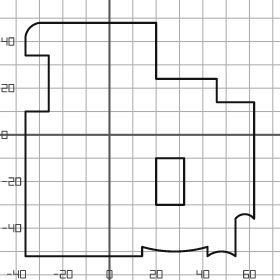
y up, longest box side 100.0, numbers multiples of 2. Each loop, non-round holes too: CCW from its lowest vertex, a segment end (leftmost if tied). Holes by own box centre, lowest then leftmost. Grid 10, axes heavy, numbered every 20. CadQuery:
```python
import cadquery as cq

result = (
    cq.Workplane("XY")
    .moveTo(-36.0, -52.0)
    .lineTo(14.0, -52.0)
    .lineTo(14.0, -48.0)
    .threePointArc((28.0, -50.0), (42.0, -48.0))
    .lineTo(42.0, -52.0)
    .threePointArc((48.0, -50.0), (54.0, -52.0))
    .lineTo(54.0, -36.0)
    .threePointArc((58.0, -34.0), (62.0, -36.0))
    .lineTo(62.0, 14.0)
    .lineTo(46.0, 14.0)
    .lineTo(46.0, 24.0)
    .lineTo(20.0, 24.0)
    .lineTo(20.0, 48.0)
    .lineTo(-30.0, 48.0)
    .threePointArc((-34.0, 46.0), (-36.0, 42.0))
    .lineTo(-36.0, 34.0)
    .lineTo(-26.0, 34.0)
    .lineTo(-26.0, 10.0)
    .lineTo(-36.0, 10.0)
    .close()
    .moveTo(20.0, -30.0)
    .lineTo(32.0, -30.0)
    .lineTo(32.0, -10.0)
    .lineTo(20.0, -10.0)
    .close()
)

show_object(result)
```